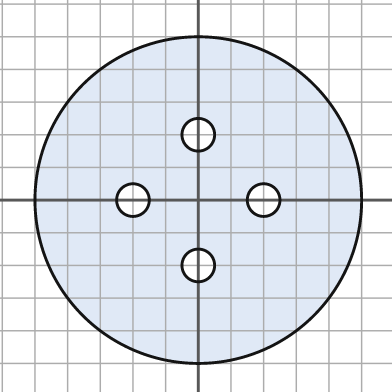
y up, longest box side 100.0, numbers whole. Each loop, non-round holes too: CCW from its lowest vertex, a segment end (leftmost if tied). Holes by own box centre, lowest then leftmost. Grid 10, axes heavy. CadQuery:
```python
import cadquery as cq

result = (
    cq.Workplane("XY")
    .moveTo(0.0, 0.0)
    .circle(50.0)
    .moveTo(0.0, -20.0)
    .circle(5.0)
    .moveTo(-20.0, 0.0)
    .circle(5.0)
    .moveTo(20.0, 0.0)
    .circle(5.0)
    .moveTo(0.0, 20.0)
    .circle(5.0)
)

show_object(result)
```